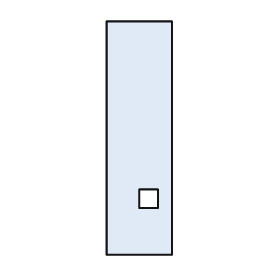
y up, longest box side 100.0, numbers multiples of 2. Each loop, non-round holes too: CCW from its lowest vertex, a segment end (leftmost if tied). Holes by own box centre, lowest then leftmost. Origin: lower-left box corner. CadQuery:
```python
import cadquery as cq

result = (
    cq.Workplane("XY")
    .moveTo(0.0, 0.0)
    .lineTo(28.0, 0.0)
    .lineTo(28.0, 100.0)
    .lineTo(0.0, 100.0)
    .close()
    .moveTo(14.0, 20.0)
    .lineTo(22.0, 20.0)
    .lineTo(22.0, 28.0)
    .lineTo(14.0, 28.0)
    .close()
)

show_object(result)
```